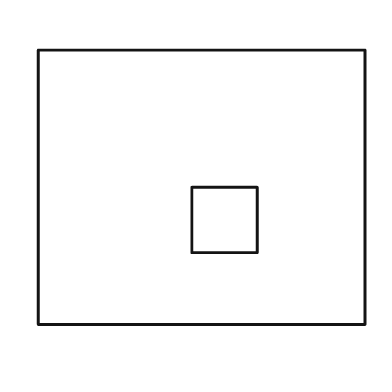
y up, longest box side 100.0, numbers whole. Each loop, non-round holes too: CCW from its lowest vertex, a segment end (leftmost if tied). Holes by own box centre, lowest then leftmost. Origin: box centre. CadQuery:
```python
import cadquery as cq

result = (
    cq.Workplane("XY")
    .moveTo(-50.0, -42.0)
    .lineTo(50.0, -42.0)
    .lineTo(50.0, 42.0)
    .lineTo(-50.0, 42.0)
    .close()
    .moveTo(-3.0, -20.0)
    .lineTo(17.0, -20.0)
    .lineTo(17.0, 0.0)
    .lineTo(-3.0, 0.0)
    .close()
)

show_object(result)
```